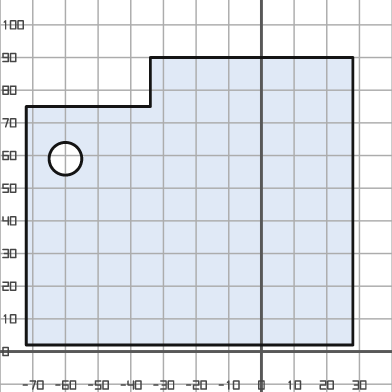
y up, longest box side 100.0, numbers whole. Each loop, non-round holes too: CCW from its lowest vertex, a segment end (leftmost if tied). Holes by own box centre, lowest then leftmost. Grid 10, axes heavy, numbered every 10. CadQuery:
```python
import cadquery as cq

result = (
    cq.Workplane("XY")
    .moveTo(-72.0, 2.0)
    .lineTo(28.0, 2.0)
    .lineTo(28.0, 90.0)
    .lineTo(-34.0, 90.0)
    .lineTo(-34.0, 75.0)
    .lineTo(-72.0, 75.0)
    .close()
    .moveTo(-60.0, 59.0)
    .circle(5.0)
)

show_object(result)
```